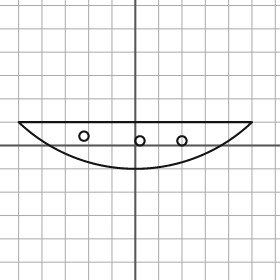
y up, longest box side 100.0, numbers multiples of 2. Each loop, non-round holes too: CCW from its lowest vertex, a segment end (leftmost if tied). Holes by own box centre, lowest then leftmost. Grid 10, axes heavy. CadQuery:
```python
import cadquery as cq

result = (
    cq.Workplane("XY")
    .moveTo(-50.0, 10.0)
    .threePointArc((0.0, -10.0), (50.0, 10.0))
    .close()
    .moveTo(2.0, 2.0)
    .circle(2.0)
    .moveTo(20.0, 2.0)
    .circle(2.0)
    .moveTo(-22.0, 4.0)
    .circle(2.0)
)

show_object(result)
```